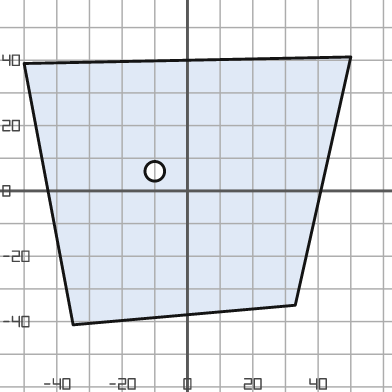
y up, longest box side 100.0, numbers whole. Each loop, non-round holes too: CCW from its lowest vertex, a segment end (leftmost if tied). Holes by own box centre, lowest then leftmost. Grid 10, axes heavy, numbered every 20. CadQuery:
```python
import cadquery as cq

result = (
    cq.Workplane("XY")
    .moveTo(-35.0, -41.0)
    .lineTo(33.0, -35.0)
    .lineTo(50.0, 41.0)
    .lineTo(-50.0, 39.0)
    .close()
    .moveTo(-10.0, 6.0)
    .circle(3.0)
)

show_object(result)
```